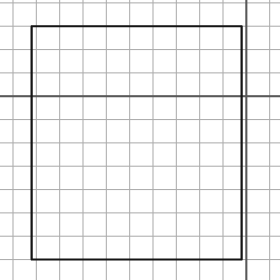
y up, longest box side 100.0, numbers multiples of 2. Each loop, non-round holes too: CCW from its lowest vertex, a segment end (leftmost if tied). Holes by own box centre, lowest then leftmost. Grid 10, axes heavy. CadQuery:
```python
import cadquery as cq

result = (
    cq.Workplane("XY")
    .moveTo(-92.0, -70.0)
    .lineTo(-2.0, -70.0)
    .lineTo(-2.0, 30.0)
    .lineTo(-92.0, 30.0)
    .close()
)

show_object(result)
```